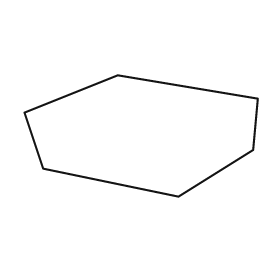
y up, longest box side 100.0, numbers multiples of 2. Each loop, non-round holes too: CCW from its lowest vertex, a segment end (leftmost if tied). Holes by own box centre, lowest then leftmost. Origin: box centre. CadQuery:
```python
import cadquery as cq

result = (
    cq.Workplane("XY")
    .moveTo(16.0, -26.0)
    .lineTo(48.0, -6.0)
    .lineTo(50.0, 16.0)
    .lineTo(-10.0, 26.0)
    .lineTo(-50.0, 10.0)
    .lineTo(-42.0, -14.0)
    .close()
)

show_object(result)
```